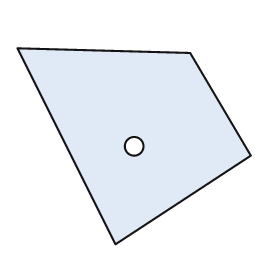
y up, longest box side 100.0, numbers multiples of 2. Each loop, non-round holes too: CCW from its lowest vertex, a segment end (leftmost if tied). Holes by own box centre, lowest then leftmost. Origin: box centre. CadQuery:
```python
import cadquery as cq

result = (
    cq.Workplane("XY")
    .moveTo(-8.0, -42.0)
    .lineTo(50.0, -4.0)
    .lineTo(24.0, 40.0)
    .lineTo(-50.0, 42.0)
    .close()
    .moveTo(0.0, 0.0)
    .circle(4.0)
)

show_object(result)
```